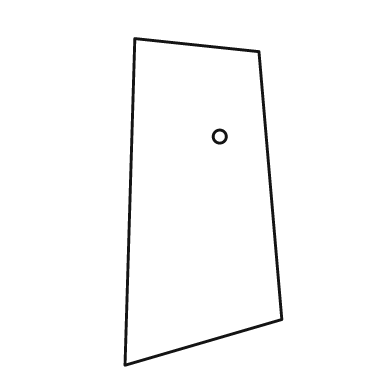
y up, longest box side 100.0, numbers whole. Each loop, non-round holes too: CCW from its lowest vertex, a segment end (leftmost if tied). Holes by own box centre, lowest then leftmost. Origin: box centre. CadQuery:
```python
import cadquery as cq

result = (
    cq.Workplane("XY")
    .moveTo(-24.0, -50.0)
    .lineTo(24.0, -36.0)
    .lineTo(17.0, 46.0)
    .lineTo(-21.0, 50.0)
    .close()
    .moveTo(5.0, 20.0)
    .circle(2.0)
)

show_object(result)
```